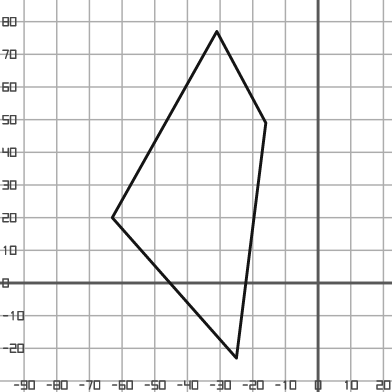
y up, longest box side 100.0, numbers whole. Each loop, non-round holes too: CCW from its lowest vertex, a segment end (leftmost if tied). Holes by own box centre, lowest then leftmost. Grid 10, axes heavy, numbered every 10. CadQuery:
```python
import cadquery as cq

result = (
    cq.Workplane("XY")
    .moveTo(-25.0, -23.0)
    .lineTo(-16.0, 49.0)
    .lineTo(-31.0, 77.0)
    .lineTo(-63.0, 20.0)
    .close()
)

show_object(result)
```